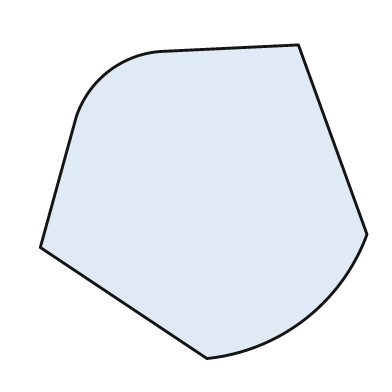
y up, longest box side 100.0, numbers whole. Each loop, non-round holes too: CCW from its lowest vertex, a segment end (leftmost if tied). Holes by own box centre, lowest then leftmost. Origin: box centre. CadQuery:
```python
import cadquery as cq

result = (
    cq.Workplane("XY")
    .moveTo(1.0, -48.0)
    .threePointArc((31.0, -36.0), (50.0, -10.0))
    .lineTo(29.0, 48.0)
    .lineTo(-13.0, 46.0)
    .threePointArc((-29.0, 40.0), (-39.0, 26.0))
    .lineTo(-50.0, -14.0)
    .close()
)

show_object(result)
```